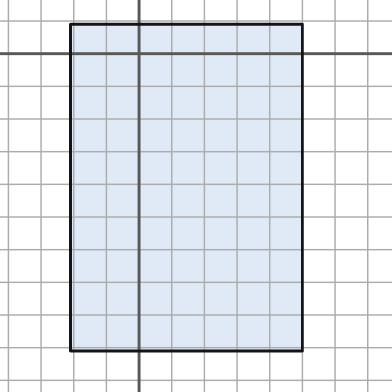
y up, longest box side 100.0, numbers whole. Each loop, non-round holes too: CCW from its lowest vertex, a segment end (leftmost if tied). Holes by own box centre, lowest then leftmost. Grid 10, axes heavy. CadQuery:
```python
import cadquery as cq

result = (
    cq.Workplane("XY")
    .moveTo(-21.0, -91.0)
    .lineTo(50.0, -91.0)
    .lineTo(50.0, 9.0)
    .lineTo(-21.0, 9.0)
    .close()
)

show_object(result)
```